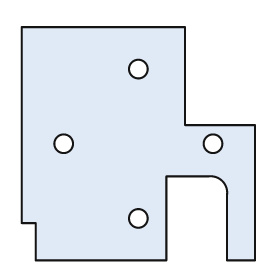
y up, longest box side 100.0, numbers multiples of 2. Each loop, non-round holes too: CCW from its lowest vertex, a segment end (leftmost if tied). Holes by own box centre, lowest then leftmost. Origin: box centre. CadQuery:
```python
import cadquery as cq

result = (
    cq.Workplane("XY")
    .moveTo(-44.0, -50.0)
    .lineTo(12.0, -50.0)
    .lineTo(12.0, -14.0)
    .lineTo(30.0, -14.0)
    .threePointArc((36.0, -16.0), (38.0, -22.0))
    .lineTo(38.0, -50.0)
    .lineTo(50.0, -50.0)
    .lineTo(50.0, 8.0)
    .lineTo(20.0, 8.0)
    .lineTo(20.0, 50.0)
    .lineTo(-50.0, 50.0)
    .lineTo(-50.0, -34.0)
    .lineTo(-44.0, -34.0)
    .close()
    .moveTo(0.0, -32.0)
    .circle(4.0)
    .moveTo(-32.0, 0.0)
    .circle(4.0)
    .moveTo(32.0, 0.0)
    .circle(4.0)
    .moveTo(0.0, 32.0)
    .circle(4.0)
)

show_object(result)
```